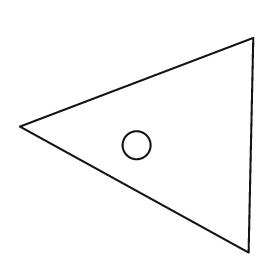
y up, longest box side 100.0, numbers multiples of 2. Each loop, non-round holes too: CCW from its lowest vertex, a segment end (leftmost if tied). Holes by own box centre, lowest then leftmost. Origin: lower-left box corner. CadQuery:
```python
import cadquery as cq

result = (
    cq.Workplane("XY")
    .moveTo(98.0, 0.0)
    .lineTo(100.0, 92.0)
    .lineTo(0.0, 54.0)
    .close()
    .moveTo(50.0, 46.0)
    .circle(6.0)
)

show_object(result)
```